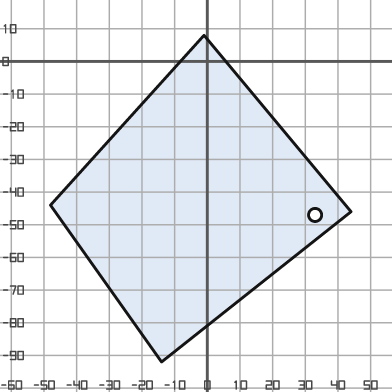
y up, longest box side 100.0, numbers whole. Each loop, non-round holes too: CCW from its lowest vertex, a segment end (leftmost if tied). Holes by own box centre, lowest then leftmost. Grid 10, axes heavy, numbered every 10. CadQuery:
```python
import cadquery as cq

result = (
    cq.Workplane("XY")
    .moveTo(-14.0, -92.0)
    .lineTo(44.0, -46.0)
    .lineTo(-1.0, 8.0)
    .lineTo(-48.0, -44.0)
    .close()
    .moveTo(33.0, -47.0)
    .circle(2.0)
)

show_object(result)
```